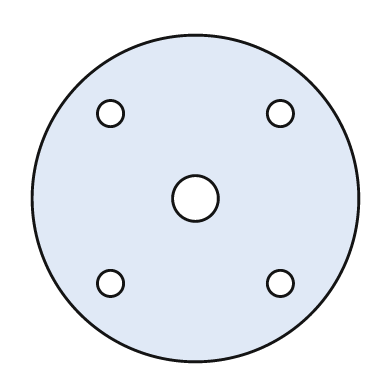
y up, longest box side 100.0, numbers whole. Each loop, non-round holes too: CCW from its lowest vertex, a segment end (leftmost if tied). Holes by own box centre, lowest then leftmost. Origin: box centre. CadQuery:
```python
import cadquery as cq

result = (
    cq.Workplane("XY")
    .moveTo(0.0, 0.0)
    .circle(50.0)
    .moveTo(-26.0, -26.0)
    .circle(4.0)
    .moveTo(26.0, -26.0)
    .circle(4.0)
    .moveTo(0.0, 0.0)
    .circle(7.0)
    .moveTo(-26.0, 26.0)
    .circle(4.0)
    .moveTo(26.0, 26.0)
    .circle(4.0)
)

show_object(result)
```